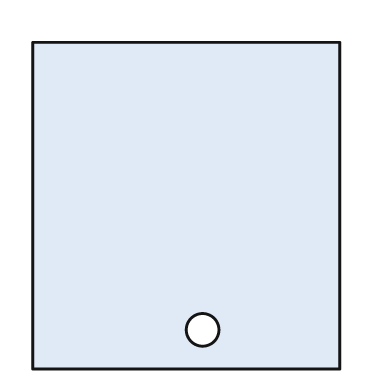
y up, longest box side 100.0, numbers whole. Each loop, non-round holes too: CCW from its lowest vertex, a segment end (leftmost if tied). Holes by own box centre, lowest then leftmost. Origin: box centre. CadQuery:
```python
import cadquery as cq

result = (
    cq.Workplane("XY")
    .moveTo(-47.0, -50.0)
    .lineTo(47.0, -50.0)
    .lineTo(47.0, 50.0)
    .lineTo(-47.0, 50.0)
    .close()
    .moveTo(5.0, -38.0)
    .circle(5.0)
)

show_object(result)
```